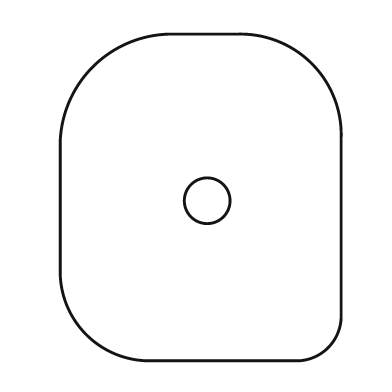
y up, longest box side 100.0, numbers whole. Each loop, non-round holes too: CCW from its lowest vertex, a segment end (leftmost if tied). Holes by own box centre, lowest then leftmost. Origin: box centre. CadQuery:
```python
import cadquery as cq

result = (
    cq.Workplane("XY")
    .moveTo(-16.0, -50.0)
    .lineTo(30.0, -50.0)
    .threePointArc((39.0, -46.0), (43.0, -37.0))
    .lineTo(43.0, 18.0)
    .threePointArc((34.0, 41.0), (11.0, 50.0))
    .lineTo(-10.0, 50.0)
    .threePointArc((-33.0, 40.0), (-43.0, 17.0))
    .lineTo(-43.0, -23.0)
    .threePointArc((-35.0, -42.0), (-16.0, -50.0))
    .close()
    .moveTo(2.0, -1.0)
    .circle(7.0)
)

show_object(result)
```